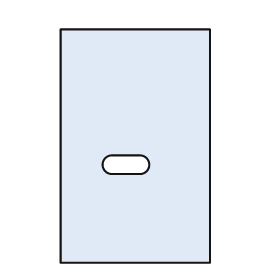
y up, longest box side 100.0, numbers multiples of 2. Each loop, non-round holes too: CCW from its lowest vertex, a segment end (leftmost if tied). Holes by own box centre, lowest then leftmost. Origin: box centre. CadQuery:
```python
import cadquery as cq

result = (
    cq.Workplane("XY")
    .moveTo(-32.0, -50.0)
    .lineTo(32.0, -50.0)
    .lineTo(32.0, 50.0)
    .lineTo(-32.0, 50.0)
    .close()
    .moveTo(-10.0, -12.0)
    .lineTo(2.0, -12.0)
    .threePointArc((6.0, -8.0), (2.0, -4.0))
    .lineTo(-10.0, -4.0)
    .threePointArc((-14.0, -8.0), (-10.0, -12.0))
    .close()
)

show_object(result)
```